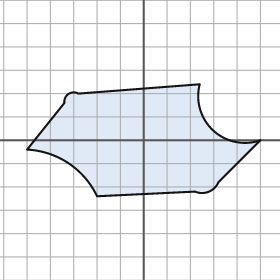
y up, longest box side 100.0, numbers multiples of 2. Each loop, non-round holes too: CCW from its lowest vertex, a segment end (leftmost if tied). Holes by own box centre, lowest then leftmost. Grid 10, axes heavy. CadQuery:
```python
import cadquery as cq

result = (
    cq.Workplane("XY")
    .moveTo(-20.0, -24.0)
    .lineTo(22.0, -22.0)
    .threePointArc((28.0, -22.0), (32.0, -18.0))
    .lineTo(50.0, 0.0)
    .threePointArc((30.0, 4.0), (24.0, 24.0))
    .lineTo(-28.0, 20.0)
    .threePointArc((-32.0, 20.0), (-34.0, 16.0))
    .lineTo(-50.0, -4.0)
    .threePointArc((-32.0, -10.0), (-20.0, -24.0))
    .close()
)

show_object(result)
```